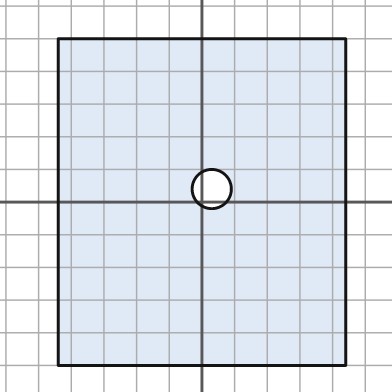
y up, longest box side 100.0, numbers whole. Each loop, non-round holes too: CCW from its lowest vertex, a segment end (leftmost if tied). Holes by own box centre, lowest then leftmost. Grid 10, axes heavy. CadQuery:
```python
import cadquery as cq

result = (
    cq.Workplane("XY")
    .moveTo(-44.0, -50.0)
    .lineTo(44.0, -50.0)
    .lineTo(44.0, 50.0)
    .lineTo(-44.0, 50.0)
    .close()
    .moveTo(3.0, 4.0)
    .circle(6.0)
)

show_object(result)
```